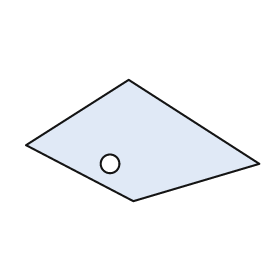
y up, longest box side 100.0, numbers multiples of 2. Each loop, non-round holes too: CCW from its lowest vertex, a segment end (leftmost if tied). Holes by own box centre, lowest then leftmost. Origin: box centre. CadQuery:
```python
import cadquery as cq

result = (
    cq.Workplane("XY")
    .moveTo(-4.0, -26.0)
    .lineTo(50.0, -10.0)
    .lineTo(-6.0, 26.0)
    .lineTo(-50.0, -2.0)
    .close()
    .moveTo(-14.0, -10.0)
    .circle(4.0)
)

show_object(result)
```